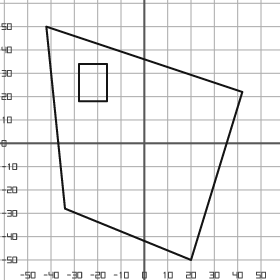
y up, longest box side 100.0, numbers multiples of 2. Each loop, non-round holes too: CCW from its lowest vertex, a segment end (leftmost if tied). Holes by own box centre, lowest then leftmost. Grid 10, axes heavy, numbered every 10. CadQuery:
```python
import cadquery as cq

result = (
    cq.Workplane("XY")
    .moveTo(20.0, -50.0)
    .lineTo(42.0, 22.0)
    .lineTo(-42.0, 50.0)
    .lineTo(-34.0, -28.0)
    .close()
    .moveTo(-28.0, 18.0)
    .lineTo(-16.0, 18.0)
    .lineTo(-16.0, 34.0)
    .lineTo(-28.0, 34.0)
    .close()
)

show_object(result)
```